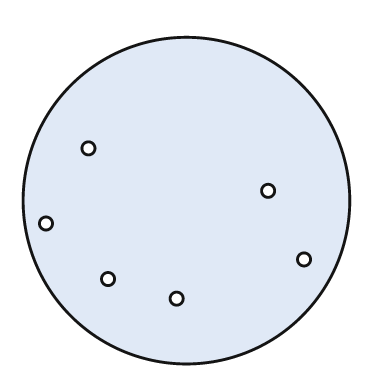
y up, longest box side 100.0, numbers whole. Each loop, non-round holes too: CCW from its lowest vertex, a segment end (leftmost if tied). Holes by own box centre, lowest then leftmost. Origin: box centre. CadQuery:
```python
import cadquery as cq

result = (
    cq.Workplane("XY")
    .moveTo(0.0, 0.0)
    .circle(50.0)
    .moveTo(-3.0, -30.0)
    .circle(2.0)
    .moveTo(-24.0, -24.0)
    .circle(2.0)
    .moveTo(36.0, -18.0)
    .circle(2.0)
    .moveTo(-43.0, -7.0)
    .circle(2.0)
    .moveTo(25.0, 3.0)
    .circle(2.0)
    .moveTo(-30.0, 16.0)
    .circle(2.0)
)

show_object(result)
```